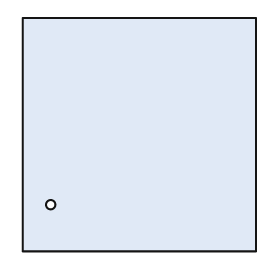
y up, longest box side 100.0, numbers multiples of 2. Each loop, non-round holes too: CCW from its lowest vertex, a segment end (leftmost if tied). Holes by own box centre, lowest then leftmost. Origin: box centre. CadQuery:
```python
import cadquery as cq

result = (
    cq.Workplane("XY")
    .moveTo(-50.0, -50.0)
    .lineTo(50.0, -50.0)
    .lineTo(50.0, 50.0)
    .lineTo(-50.0, 50.0)
    .close()
    .moveTo(-38.0, -30.0)
    .circle(2.0)
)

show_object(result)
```